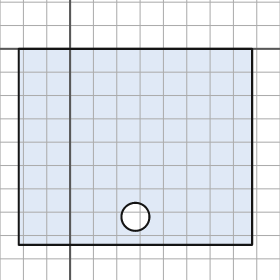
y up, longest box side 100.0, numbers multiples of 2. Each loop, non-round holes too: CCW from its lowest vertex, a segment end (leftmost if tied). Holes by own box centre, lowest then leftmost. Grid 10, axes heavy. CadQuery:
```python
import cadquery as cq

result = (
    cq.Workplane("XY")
    .moveTo(-22.0, -84.0)
    .lineTo(78.0, -84.0)
    .lineTo(78.0, 0.0)
    .lineTo(-22.0, 0.0)
    .close()
    .moveTo(28.0, -72.0)
    .circle(6.0)
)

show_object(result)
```